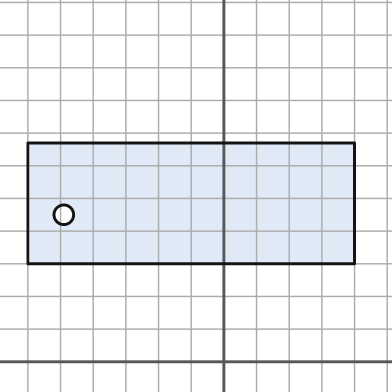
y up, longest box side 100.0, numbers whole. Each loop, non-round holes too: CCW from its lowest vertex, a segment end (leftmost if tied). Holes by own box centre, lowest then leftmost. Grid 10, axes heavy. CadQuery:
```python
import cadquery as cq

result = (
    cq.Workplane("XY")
    .moveTo(-60.0, 30.0)
    .lineTo(40.0, 30.0)
    .lineTo(40.0, 67.0)
    .lineTo(-60.0, 67.0)
    .close()
    .moveTo(-49.0, 45.0)
    .circle(3.0)
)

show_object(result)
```